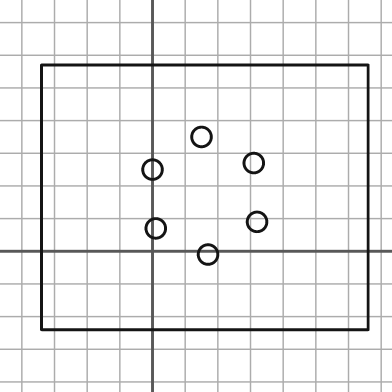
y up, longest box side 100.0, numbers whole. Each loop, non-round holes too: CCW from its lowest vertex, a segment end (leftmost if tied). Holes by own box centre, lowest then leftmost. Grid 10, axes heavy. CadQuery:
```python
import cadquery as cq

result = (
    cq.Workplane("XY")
    .moveTo(-34.0, -24.0)
    .lineTo(66.0, -24.0)
    .lineTo(66.0, 57.0)
    .lineTo(-34.0, 57.0)
    .close()
    .moveTo(17.0, -1.0)
    .circle(3.0)
    .moveTo(1.0, 7.0)
    .circle(3.0)
    .moveTo(32.0, 9.0)
    .circle(3.0)
    .moveTo(0.0, 25.0)
    .circle(3.0)
    .moveTo(31.0, 27.0)
    .circle(3.0)
    .moveTo(15.0, 35.0)
    .circle(3.0)
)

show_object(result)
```